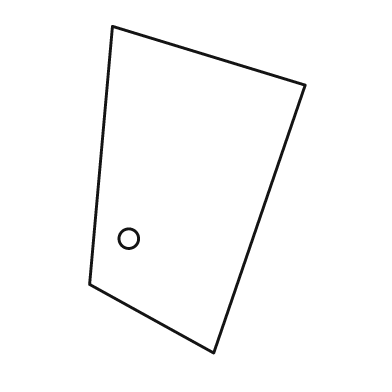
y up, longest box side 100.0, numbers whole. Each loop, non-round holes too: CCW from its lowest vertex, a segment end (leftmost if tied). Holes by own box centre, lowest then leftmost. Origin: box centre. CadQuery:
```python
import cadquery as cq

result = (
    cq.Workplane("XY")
    .moveTo(5.0, -50.0)
    .lineTo(33.0, 32.0)
    .lineTo(-26.0, 50.0)
    .lineTo(-33.0, -29.0)
    .close()
    .moveTo(-21.0, -15.0)
    .circle(3.0)
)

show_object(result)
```